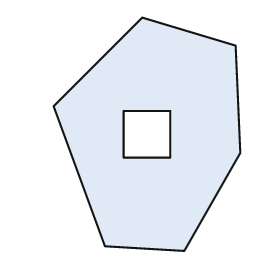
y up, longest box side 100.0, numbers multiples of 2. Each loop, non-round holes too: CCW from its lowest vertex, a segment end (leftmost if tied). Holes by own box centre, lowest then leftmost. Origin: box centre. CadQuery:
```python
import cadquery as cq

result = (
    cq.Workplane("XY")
    .moveTo(16.0, -50.0)
    .lineTo(40.0, -8.0)
    .lineTo(38.0, 38.0)
    .lineTo(-2.0, 50.0)
    .lineTo(-40.0, 12.0)
    .lineTo(-18.0, -48.0)
    .close()
    .moveTo(-10.0, -10.0)
    .lineTo(10.0, -10.0)
    .lineTo(10.0, 10.0)
    .lineTo(-10.0, 10.0)
    .close()
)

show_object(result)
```